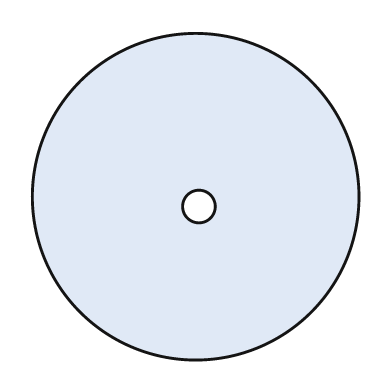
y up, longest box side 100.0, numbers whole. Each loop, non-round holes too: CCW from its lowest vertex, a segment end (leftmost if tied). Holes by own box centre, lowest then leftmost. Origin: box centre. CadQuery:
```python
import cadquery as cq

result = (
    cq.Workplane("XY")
    .moveTo(0.0, 0.0)
    .circle(50.0)
    .moveTo(1.0, -3.0)
    .circle(5.0)
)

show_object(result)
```